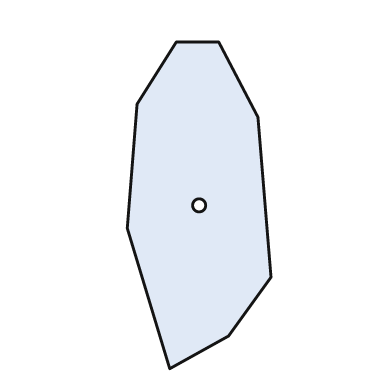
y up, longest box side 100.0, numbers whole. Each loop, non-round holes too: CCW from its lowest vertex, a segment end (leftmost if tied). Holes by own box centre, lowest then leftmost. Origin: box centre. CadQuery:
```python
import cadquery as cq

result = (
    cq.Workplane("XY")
    .moveTo(-9.0, -50.0)
    .lineTo(9.0, -40.0)
    .lineTo(22.0, -22.0)
    .lineTo(18.0, 27.0)
    .lineTo(6.0, 50.0)
    .lineTo(-7.0, 50.0)
    .lineTo(-19.0, 31.0)
    .lineTo(-22.0, -7.0)
    .close()
    .moveTo(0.0, 0.0)
    .circle(2.0)
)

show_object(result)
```